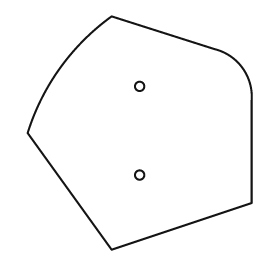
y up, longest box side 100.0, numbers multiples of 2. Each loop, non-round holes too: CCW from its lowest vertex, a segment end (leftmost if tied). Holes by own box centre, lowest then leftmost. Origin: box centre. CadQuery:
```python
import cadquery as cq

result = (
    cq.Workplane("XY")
    .moveTo(-12.0, -50.0)
    .lineTo(48.0, -30.0)
    .lineTo(48.0, 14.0)
    .threePointArc((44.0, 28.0), (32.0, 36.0))
    .lineTo(-12.0, 50.0)
    .threePointArc((-34.0, 28.0), (-48.0, 0.0))
    .close()
    .moveTo(0.0, -18.0)
    .circle(2.0)
    .moveTo(0.0, 20.0)
    .circle(2.0)
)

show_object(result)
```